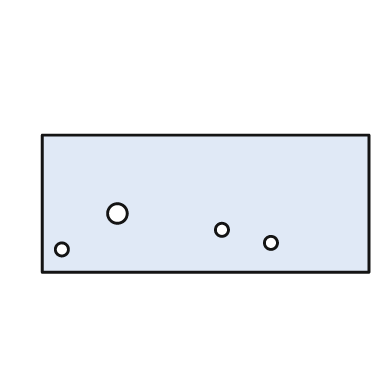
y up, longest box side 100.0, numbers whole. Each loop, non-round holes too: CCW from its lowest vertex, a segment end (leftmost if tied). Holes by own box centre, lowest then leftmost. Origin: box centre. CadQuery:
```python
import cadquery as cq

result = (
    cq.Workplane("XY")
    .moveTo(-50.0, -21.0)
    .lineTo(50.0, -21.0)
    .lineTo(50.0, 21.0)
    .lineTo(-50.0, 21.0)
    .close()
    .moveTo(-44.0, -14.0)
    .circle(2.0)
    .moveTo(20.0, -12.0)
    .circle(2.0)
    .moveTo(5.0, -8.0)
    .circle(2.0)
    .moveTo(-27.0, -3.0)
    .circle(3.0)
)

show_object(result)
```